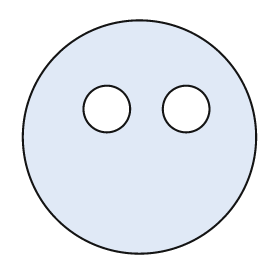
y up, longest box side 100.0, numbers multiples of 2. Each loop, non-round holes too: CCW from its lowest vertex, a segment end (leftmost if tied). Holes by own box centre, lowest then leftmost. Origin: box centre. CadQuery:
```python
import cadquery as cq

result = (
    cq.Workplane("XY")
    .moveTo(0.0, 0.0)
    .circle(50.0)
    .moveTo(-14.0, 12.0)
    .circle(10.0)
    .moveTo(20.0, 12.0)
    .circle(10.0)
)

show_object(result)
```